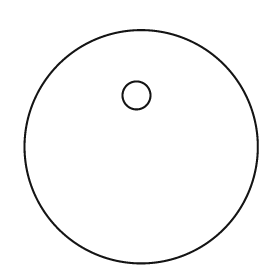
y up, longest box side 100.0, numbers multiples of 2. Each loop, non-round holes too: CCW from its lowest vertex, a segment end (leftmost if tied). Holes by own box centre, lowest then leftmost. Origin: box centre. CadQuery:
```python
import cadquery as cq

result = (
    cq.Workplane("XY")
    .moveTo(0.0, 0.0)
    .circle(50.0)
    .moveTo(-2.0, 22.0)
    .circle(6.0)
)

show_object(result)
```